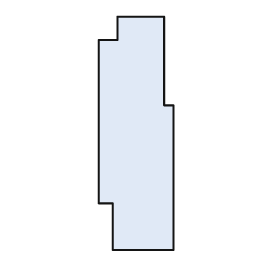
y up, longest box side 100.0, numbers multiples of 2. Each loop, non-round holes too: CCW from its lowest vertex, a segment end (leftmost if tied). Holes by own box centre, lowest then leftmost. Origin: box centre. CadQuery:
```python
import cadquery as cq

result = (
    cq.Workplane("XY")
    .moveTo(-10.0, -50.0)
    .lineTo(16.0, -50.0)
    .lineTo(16.0, 12.0)
    .lineTo(12.0, 12.0)
    .lineTo(12.0, 50.0)
    .lineTo(-8.0, 50.0)
    .lineTo(-8.0, 40.0)
    .lineTo(-16.0, 40.0)
    .lineTo(-16.0, -30.0)
    .lineTo(-10.0, -30.0)
    .close()
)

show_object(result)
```